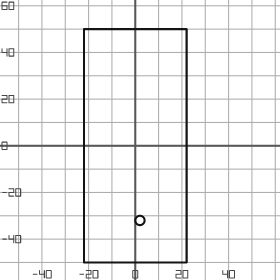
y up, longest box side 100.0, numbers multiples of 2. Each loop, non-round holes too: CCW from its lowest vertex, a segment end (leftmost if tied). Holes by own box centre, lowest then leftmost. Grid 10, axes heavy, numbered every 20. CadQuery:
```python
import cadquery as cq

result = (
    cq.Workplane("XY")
    .moveTo(-22.0, -50.0)
    .lineTo(22.0, -50.0)
    .lineTo(22.0, 50.0)
    .lineTo(-22.0, 50.0)
    .close()
    .moveTo(2.0, -32.0)
    .circle(2.0)
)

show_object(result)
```